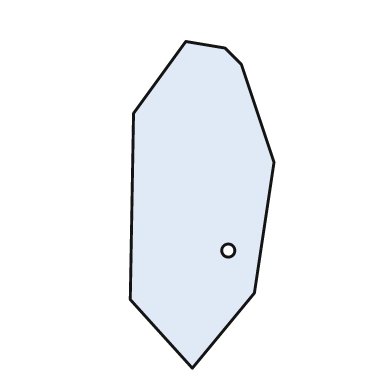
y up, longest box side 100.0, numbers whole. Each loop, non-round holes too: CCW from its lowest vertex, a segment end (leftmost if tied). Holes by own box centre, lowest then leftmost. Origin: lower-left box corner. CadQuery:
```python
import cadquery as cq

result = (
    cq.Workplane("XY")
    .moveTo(19.0, 0.0)
    .lineTo(38.0, 23.0)
    .lineTo(44.0, 63.0)
    .lineTo(34.0, 93.0)
    .lineTo(29.0, 98.0)
    .lineTo(17.0, 100.0)
    .lineTo(1.0, 78.0)
    .lineTo(0.0, 21.0)
    .close()
    .moveTo(30.0, 36.0)
    .circle(2.0)
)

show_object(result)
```